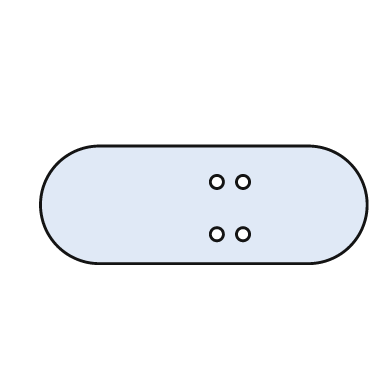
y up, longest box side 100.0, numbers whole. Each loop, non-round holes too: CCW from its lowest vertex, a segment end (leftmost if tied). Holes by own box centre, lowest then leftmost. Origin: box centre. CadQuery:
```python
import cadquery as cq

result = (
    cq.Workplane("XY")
    .moveTo(-32.0, -18.0)
    .lineTo(32.0, -18.0)
    .threePointArc((50.0, 0.0), (32.0, 18.0))
    .lineTo(-32.0, 18.0)
    .threePointArc((-50.0, 0.0), (-32.0, -18.0))
    .close()
    .moveTo(4.0, -9.0)
    .circle(2.0)
    .moveTo(12.0, -9.0)
    .circle(2.0)
    .moveTo(4.0, 7.0)
    .circle(2.0)
    .moveTo(12.0, 7.0)
    .circle(2.0)
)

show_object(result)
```